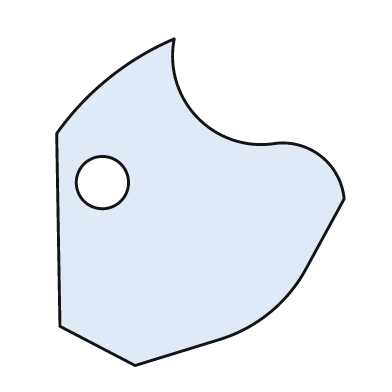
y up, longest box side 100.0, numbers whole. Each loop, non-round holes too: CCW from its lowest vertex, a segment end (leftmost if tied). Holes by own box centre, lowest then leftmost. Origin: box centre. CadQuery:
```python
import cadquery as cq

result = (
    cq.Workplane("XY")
    .moveTo(-20.0, -50.0)
    .lineTo(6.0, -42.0)
    .threePointArc((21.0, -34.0), (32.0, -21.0))
    .lineTo(44.0, 1.0)
    .threePointArc((37.0, 14.0), (23.0, 18.0))
    .threePointArc((-1.0, 26.0), (-8.0, 50.0))
    .threePointArc((-28.0, 38.0), (-44.0, 21.0))
    .lineTo(-43.0, -38.0)
    .close()
    .moveTo(-30.0, 6.0)
    .circle(8.0)
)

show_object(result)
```